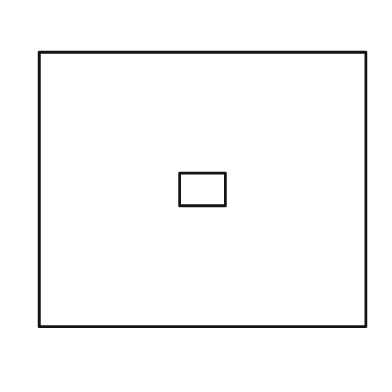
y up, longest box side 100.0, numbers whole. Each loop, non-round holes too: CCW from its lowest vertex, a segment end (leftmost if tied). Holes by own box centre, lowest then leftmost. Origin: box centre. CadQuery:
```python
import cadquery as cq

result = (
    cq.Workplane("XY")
    .moveTo(-50.0, -42.0)
    .lineTo(50.0, -42.0)
    .lineTo(50.0, 42.0)
    .lineTo(-50.0, 42.0)
    .close()
    .moveTo(-7.0, -5.0)
    .lineTo(7.0, -5.0)
    .lineTo(7.0, 5.0)
    .lineTo(-7.0, 5.0)
    .close()
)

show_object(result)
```